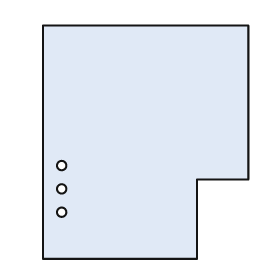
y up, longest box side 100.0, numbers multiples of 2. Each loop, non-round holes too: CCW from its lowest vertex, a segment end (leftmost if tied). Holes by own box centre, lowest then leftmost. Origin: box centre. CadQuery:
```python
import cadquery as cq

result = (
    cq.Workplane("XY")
    .moveTo(-44.0, -50.0)
    .lineTo(22.0, -50.0)
    .lineTo(22.0, -16.0)
    .lineTo(44.0, -16.0)
    .lineTo(44.0, 50.0)
    .lineTo(-44.0, 50.0)
    .close()
    .moveTo(-36.0, -30.0)
    .circle(2.0)
    .moveTo(-36.0, -20.0)
    .circle(2.0)
    .moveTo(-36.0, -10.0)
    .circle(2.0)
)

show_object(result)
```